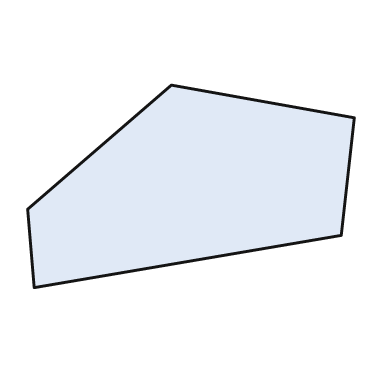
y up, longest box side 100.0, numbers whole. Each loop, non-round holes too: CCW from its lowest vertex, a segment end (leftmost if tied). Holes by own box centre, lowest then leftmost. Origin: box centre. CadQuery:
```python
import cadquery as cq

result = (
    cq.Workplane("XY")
    .moveTo(-48.0, -31.0)
    .lineTo(46.0, -15.0)
    .lineTo(50.0, 21.0)
    .lineTo(-6.0, 31.0)
    .lineTo(-50.0, -7.0)
    .close()
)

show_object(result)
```